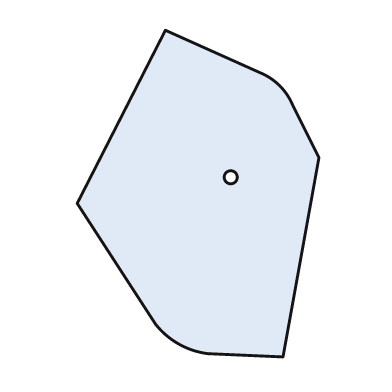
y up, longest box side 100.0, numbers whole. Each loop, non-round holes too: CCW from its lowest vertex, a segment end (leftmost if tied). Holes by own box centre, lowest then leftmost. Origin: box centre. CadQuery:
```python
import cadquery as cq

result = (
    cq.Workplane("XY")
    .moveTo(26.0, -50.0)
    .lineTo(37.0, 11.0)
    .lineTo(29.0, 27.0)
    .threePointArc((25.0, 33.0), (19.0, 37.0))
    .lineTo(-10.0, 50.0)
    .lineTo(-37.0, -3.0)
    .lineTo(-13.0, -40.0)
    .threePointArc((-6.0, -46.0), (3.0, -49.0))
    .close()
    .moveTo(10.0, 5.0)
    .circle(2.0)
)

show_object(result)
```